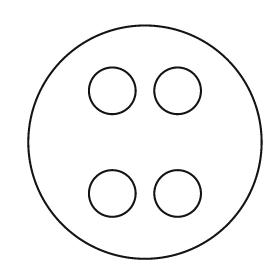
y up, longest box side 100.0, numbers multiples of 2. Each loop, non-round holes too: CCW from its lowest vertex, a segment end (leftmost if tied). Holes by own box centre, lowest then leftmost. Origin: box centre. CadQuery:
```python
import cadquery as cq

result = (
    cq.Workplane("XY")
    .moveTo(0.0, 0.0)
    .circle(50.0)
    .moveTo(-14.0, -22.0)
    .circle(10.0)
    .moveTo(14.0, -22.0)
    .circle(10.0)
    .moveTo(-14.0, 22.0)
    .circle(10.0)
    .moveTo(14.0, 22.0)
    .circle(10.0)
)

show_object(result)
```